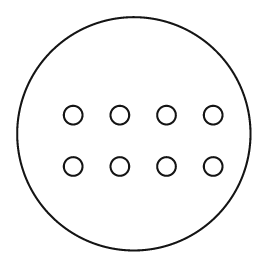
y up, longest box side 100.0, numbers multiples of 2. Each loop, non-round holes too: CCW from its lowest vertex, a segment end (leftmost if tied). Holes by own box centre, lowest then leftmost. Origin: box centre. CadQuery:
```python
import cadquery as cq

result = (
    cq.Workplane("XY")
    .moveTo(0.0, 0.0)
    .circle(50.0)
    .moveTo(-26.0, -14.0)
    .circle(4.0)
    .moveTo(-6.0, -14.0)
    .circle(4.0)
    .moveTo(14.0, -14.0)
    .circle(4.0)
    .moveTo(34.0, -14.0)
    .circle(4.0)
    .moveTo(-26.0, 8.0)
    .circle(4.0)
    .moveTo(-6.0, 8.0)
    .circle(4.0)
    .moveTo(14.0, 8.0)
    .circle(4.0)
    .moveTo(34.0, 8.0)
    .circle(4.0)
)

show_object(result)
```